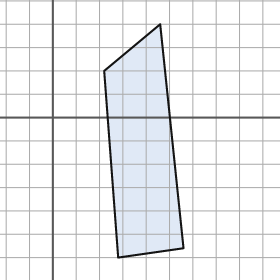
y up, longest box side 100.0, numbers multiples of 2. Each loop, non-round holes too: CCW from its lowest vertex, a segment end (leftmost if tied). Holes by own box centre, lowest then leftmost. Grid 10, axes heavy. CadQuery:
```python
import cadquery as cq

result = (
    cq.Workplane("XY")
    .moveTo(28.0, -60.0)
    .lineTo(56.0, -56.0)
    .lineTo(46.0, 40.0)
    .lineTo(22.0, 20.0)
    .close()
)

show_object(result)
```